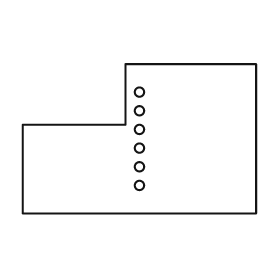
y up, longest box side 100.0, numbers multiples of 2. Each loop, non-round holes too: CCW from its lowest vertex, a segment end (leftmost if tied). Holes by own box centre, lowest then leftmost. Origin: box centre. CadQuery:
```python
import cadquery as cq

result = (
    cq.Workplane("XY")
    .moveTo(-50.0, -32.0)
    .lineTo(50.0, -32.0)
    .lineTo(50.0, 32.0)
    .lineTo(-6.0, 32.0)
    .lineTo(-6.0, 6.0)
    .lineTo(-50.0, 6.0)
    .close()
    .moveTo(0.0, -20.0)
    .circle(2.0)
    .moveTo(0.0, -12.0)
    .circle(2.0)
    .moveTo(0.0, -4.0)
    .circle(2.0)
    .moveTo(0.0, 4.0)
    .circle(2.0)
    .moveTo(0.0, 12.0)
    .circle(2.0)
    .moveTo(0.0, 20.0)
    .circle(2.0)
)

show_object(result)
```